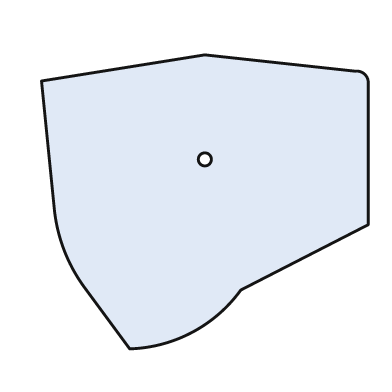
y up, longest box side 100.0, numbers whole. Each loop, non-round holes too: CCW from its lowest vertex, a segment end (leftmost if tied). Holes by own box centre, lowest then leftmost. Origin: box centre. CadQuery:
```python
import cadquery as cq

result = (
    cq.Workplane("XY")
    .moveTo(-23.0, -45.0)
    .threePointArc((-4.0, -40.0), (11.0, -27.0))
    .lineTo(50.0, -7.0)
    .lineTo(50.0, 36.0)
    .threePointArc((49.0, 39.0), (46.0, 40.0))
    .lineTo(0.0, 45.0)
    .lineTo(-50.0, 37.0)
    .lineTo(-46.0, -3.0)
    .threePointArc((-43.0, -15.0), (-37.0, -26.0))
    .close()
    .moveTo(0.0, 13.0)
    .circle(2.0)
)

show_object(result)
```